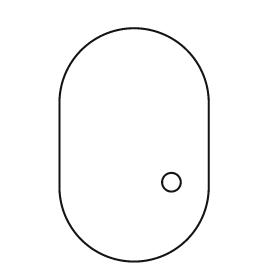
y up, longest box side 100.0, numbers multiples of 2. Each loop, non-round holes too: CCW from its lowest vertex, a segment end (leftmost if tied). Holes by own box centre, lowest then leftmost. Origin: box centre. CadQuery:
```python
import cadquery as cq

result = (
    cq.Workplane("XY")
    .moveTo(-32.0, -18.0)
    .threePointArc((0.0, -50.0), (32.0, -18.0))
    .lineTo(32.0, 18.0)
    .threePointArc((0.0, 50.0), (-32.0, 18.0))
    .close()
    .moveTo(16.0, -16.0)
    .circle(4.0)
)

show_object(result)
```